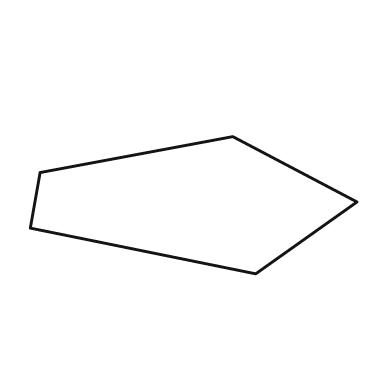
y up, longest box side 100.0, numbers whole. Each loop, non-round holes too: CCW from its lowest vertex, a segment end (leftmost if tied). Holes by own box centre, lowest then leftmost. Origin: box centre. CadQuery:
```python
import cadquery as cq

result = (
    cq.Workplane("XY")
    .moveTo(19.0, -21.0)
    .lineTo(50.0, 1.0)
    .lineTo(12.0, 21.0)
    .lineTo(-47.0, 10.0)
    .lineTo(-50.0, -7.0)
    .close()
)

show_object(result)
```